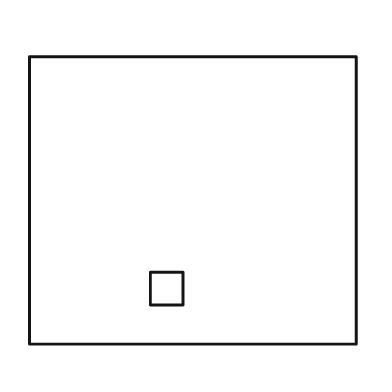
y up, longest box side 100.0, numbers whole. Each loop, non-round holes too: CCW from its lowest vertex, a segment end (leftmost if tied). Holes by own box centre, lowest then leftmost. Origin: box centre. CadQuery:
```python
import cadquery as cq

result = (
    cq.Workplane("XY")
    .moveTo(-50.0, -44.0)
    .lineTo(50.0, -44.0)
    .lineTo(50.0, 44.0)
    .lineTo(-50.0, 44.0)
    .close()
    .moveTo(-13.0, -32.0)
    .lineTo(-3.0, -32.0)
    .lineTo(-3.0, -22.0)
    .lineTo(-13.0, -22.0)
    .close()
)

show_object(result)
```